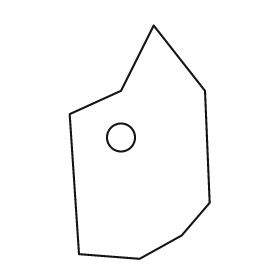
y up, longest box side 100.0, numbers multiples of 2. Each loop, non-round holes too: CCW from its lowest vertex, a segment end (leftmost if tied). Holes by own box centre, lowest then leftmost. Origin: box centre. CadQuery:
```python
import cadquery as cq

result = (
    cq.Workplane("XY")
    .moveTo(0.0, -50.0)
    .lineTo(18.0, -40.0)
    .lineTo(30.0, -26.0)
    .lineTo(28.0, 22.0)
    .lineTo(6.0, 50.0)
    .lineTo(-8.0, 22.0)
    .lineTo(-30.0, 12.0)
    .lineTo(-26.0, -48.0)
    .close()
    .moveTo(-8.0, 2.0)
    .circle(6.0)
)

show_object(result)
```